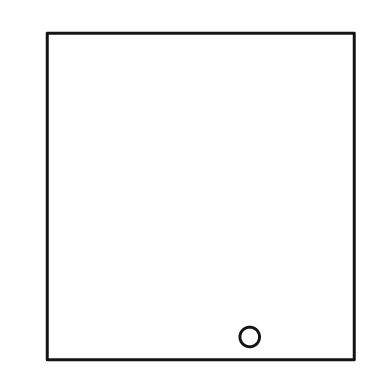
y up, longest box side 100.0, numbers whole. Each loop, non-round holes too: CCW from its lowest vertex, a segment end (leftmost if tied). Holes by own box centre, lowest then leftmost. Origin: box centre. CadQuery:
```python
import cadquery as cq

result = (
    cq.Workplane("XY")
    .moveTo(-47.0, -50.0)
    .lineTo(47.0, -50.0)
    .lineTo(47.0, 50.0)
    .lineTo(-47.0, 50.0)
    .close()
    .moveTo(15.0, -43.0)
    .circle(3.0)
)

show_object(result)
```